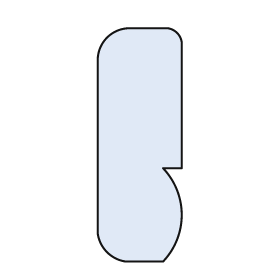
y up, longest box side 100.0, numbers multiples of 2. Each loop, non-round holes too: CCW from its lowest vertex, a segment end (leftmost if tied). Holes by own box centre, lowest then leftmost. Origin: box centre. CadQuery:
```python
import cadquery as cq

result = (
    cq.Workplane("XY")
    .moveTo(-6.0, -50.0)
    .lineTo(10.0, -50.0)
    .threePointArc((18.0, -30.0), (10.0, -10.0))
    .lineTo(18.0, -10.0)
    .lineTo(18.0, 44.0)
    .threePointArc((16.0, 48.0), (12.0, 50.0))
    .lineTo(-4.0, 50.0)
    .threePointArc((-14.0, 46.0), (-18.0, 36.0))
    .lineTo(-18.0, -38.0)
    .threePointArc((-14.0, -46.0), (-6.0, -50.0))
    .close()
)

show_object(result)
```